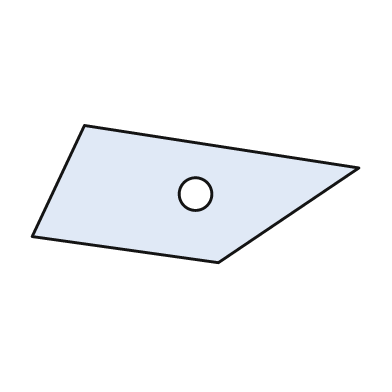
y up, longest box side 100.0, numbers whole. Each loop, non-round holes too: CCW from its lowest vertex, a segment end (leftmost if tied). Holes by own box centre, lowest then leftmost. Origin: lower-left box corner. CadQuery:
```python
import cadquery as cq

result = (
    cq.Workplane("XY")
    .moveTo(57.0, 0.0)
    .lineTo(100.0, 29.0)
    .lineTo(16.0, 42.0)
    .lineTo(0.0, 8.0)
    .close()
    .moveTo(50.0, 21.0)
    .circle(5.0)
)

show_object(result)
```